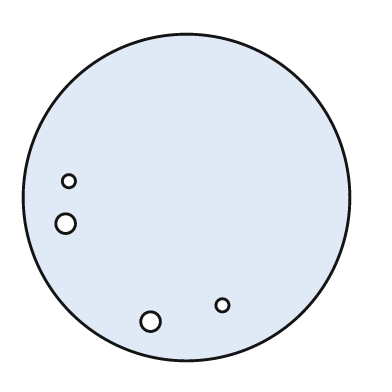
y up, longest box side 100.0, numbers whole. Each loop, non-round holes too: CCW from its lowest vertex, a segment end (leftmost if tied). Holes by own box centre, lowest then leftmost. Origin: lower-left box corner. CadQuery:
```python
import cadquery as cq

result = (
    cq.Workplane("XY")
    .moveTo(50.0, 50.0)
    .circle(50.0)
    .moveTo(39.0, 12.0)
    .circle(3.0)
    .moveTo(61.0, 17.0)
    .circle(2.0)
    .moveTo(13.0, 42.0)
    .circle(3.0)
    .moveTo(14.0, 55.0)
    .circle(2.0)
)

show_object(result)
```